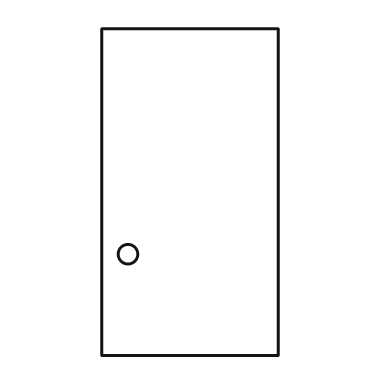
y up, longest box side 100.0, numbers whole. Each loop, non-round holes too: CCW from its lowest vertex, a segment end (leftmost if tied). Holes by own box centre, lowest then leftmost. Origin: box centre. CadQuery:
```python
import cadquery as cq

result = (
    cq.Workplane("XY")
    .moveTo(-27.0, -50.0)
    .lineTo(27.0, -50.0)
    .lineTo(27.0, 50.0)
    .lineTo(-27.0, 50.0)
    .close()
    .moveTo(-19.0, -19.0)
    .circle(3.0)
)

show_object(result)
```